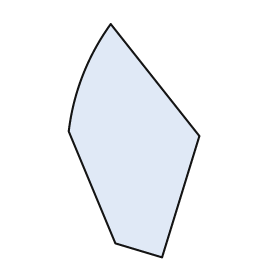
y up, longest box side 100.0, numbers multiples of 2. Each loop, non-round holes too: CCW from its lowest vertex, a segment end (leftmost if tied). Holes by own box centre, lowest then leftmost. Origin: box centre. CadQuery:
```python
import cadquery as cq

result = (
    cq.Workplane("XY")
    .moveTo(12.0, -50.0)
    .lineTo(28.0, 2.0)
    .lineTo(-10.0, 50.0)
    .threePointArc((-22.0, 28.0), (-28.0, 4.0))
    .lineTo(-8.0, -44.0)
    .close()
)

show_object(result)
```